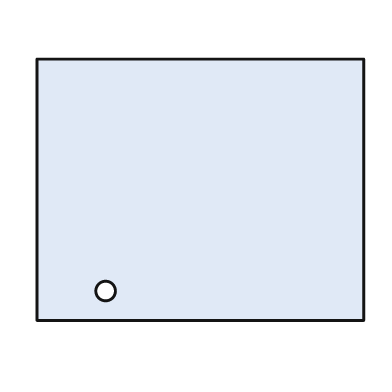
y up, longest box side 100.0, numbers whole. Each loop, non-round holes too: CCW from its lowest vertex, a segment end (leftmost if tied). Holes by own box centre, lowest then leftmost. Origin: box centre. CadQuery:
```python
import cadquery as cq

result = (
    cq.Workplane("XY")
    .moveTo(-50.0, -40.0)
    .lineTo(50.0, -40.0)
    .lineTo(50.0, 40.0)
    .lineTo(-50.0, 40.0)
    .close()
    .moveTo(-29.0, -31.0)
    .circle(3.0)
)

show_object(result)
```